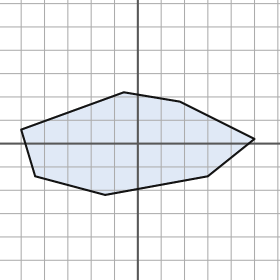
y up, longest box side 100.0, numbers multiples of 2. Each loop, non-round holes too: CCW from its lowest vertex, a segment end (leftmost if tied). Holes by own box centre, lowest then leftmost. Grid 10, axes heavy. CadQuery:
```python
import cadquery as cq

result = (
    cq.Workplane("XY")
    .moveTo(-14.0, -22.0)
    .lineTo(30.0, -14.0)
    .lineTo(50.0, 2.0)
    .lineTo(18.0, 18.0)
    .lineTo(-6.0, 22.0)
    .lineTo(-50.0, 6.0)
    .lineTo(-44.0, -14.0)
    .close()
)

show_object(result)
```